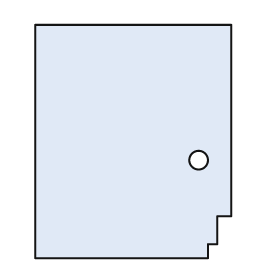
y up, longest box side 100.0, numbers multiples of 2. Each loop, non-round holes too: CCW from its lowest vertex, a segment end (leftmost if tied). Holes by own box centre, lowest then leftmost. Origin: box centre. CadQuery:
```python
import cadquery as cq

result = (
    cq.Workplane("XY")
    .moveTo(-42.0, -50.0)
    .lineTo(32.0, -50.0)
    .lineTo(32.0, -44.0)
    .lineTo(36.0, -44.0)
    .lineTo(36.0, -32.0)
    .lineTo(42.0, -32.0)
    .lineTo(42.0, 50.0)
    .lineTo(-42.0, 50.0)
    .close()
    .moveTo(28.0, -8.0)
    .circle(4.0)
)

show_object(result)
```